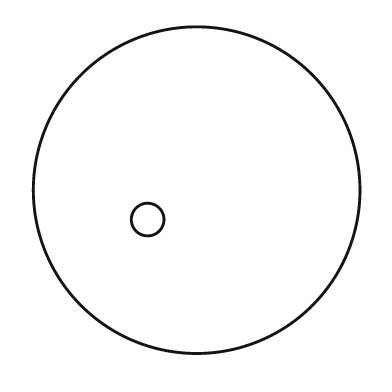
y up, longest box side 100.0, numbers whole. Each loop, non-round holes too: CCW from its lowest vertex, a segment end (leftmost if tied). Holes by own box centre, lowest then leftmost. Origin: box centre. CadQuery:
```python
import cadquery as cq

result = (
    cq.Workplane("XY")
    .moveTo(0.0, 0.0)
    .circle(50.0)
    .moveTo(-15.0, -9.0)
    .circle(5.0)
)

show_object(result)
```